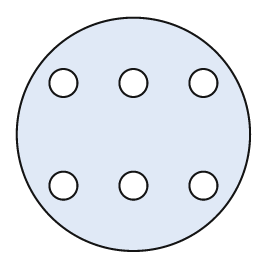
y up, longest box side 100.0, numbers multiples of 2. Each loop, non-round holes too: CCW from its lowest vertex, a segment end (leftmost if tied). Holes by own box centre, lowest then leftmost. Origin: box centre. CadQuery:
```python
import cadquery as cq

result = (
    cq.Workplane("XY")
    .moveTo(0.0, 0.0)
    .circle(50.0)
    .moveTo(-30.0, -22.0)
    .circle(6.0)
    .moveTo(0.0, -22.0)
    .circle(6.0)
    .moveTo(30.0, -22.0)
    .circle(6.0)
    .moveTo(-30.0, 22.0)
    .circle(6.0)
    .moveTo(0.0, 22.0)
    .circle(6.0)
    .moveTo(30.0, 22.0)
    .circle(6.0)
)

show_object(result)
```